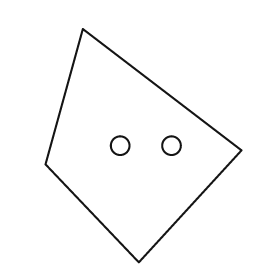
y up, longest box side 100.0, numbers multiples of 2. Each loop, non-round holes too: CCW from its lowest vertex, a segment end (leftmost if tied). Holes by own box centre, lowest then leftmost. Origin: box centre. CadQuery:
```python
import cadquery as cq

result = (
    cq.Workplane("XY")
    .moveTo(-2.0, -50.0)
    .lineTo(42.0, -2.0)
    .lineTo(-26.0, 50.0)
    .lineTo(-42.0, -8.0)
    .close()
    .moveTo(-10.0, 0.0)
    .circle(4.0)
    .moveTo(12.0, 0.0)
    .circle(4.0)
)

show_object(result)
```